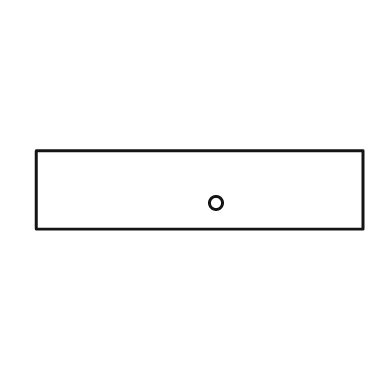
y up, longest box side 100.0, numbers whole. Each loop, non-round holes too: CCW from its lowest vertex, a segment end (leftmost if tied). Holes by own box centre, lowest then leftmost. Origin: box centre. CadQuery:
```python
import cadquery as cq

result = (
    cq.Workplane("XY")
    .moveTo(-50.0, -12.0)
    .lineTo(50.0, -12.0)
    .lineTo(50.0, 12.0)
    .lineTo(-50.0, 12.0)
    .close()
    .moveTo(5.0, -4.0)
    .circle(2.0)
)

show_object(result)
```